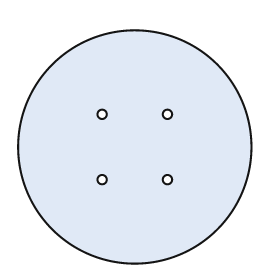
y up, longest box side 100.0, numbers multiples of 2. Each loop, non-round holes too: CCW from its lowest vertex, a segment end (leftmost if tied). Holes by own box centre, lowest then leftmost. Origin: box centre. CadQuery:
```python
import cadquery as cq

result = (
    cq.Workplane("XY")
    .moveTo(0.0, 0.0)
    .circle(50.0)
    .moveTo(-14.0, -14.0)
    .circle(2.0)
    .moveTo(14.0, -14.0)
    .circle(2.0)
    .moveTo(-14.0, 14.0)
    .circle(2.0)
    .moveTo(14.0, 14.0)
    .circle(2.0)
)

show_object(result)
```